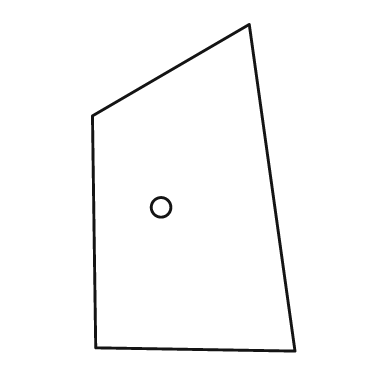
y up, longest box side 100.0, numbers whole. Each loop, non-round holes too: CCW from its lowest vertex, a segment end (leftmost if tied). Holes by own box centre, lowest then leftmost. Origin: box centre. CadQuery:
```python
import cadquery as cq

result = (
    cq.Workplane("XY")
    .moveTo(31.0, -50.0)
    .lineTo(17.0, 50.0)
    .lineTo(-31.0, 22.0)
    .lineTo(-30.0, -49.0)
    .close()
    .moveTo(-10.0, -6.0)
    .circle(3.0)
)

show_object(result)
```